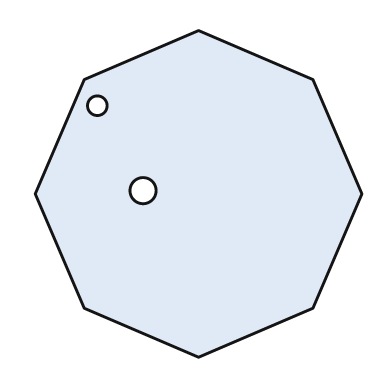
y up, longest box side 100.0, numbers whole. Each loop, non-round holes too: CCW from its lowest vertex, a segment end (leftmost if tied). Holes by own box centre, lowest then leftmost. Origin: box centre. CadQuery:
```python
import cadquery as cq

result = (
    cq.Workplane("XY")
    .moveTo(0.0, -50.0)
    .lineTo(35.0, -35.0)
    .lineTo(50.0, 0.0)
    .lineTo(35.0, 35.0)
    .lineTo(0.0, 50.0)
    .lineTo(-35.0, 35.0)
    .lineTo(-50.0, 0.0)
    .lineTo(-35.0, -35.0)
    .close()
    .moveTo(-17.0, 1.0)
    .circle(4.0)
    .moveTo(-31.0, 27.0)
    .circle(3.0)
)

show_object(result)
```